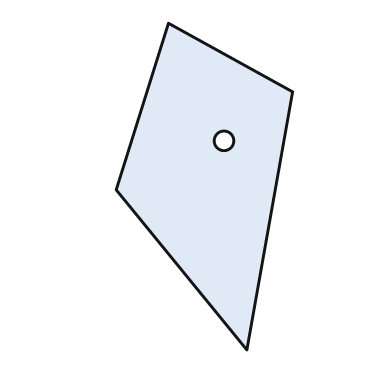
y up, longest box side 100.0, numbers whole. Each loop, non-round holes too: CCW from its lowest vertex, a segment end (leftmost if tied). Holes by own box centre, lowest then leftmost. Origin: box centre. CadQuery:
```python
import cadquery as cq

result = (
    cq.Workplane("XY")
    .moveTo(13.0, -50.0)
    .lineTo(27.0, 29.0)
    .lineTo(-11.0, 50.0)
    .lineTo(-27.0, -1.0)
    .close()
    .moveTo(6.0, 14.0)
    .circle(3.0)
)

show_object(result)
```